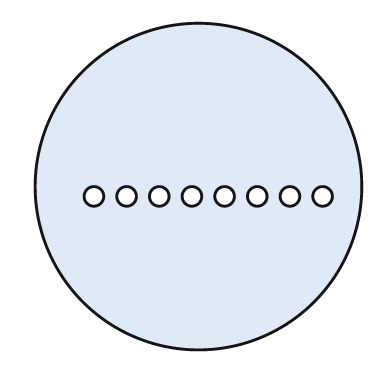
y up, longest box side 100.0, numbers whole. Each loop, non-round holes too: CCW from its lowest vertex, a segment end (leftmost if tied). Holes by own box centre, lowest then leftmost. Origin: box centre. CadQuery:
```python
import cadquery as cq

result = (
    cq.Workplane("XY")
    .moveTo(0.0, 0.0)
    .circle(50.0)
    .moveTo(-32.0, -3.0)
    .circle(3.0)
    .moveTo(-22.0, -3.0)
    .circle(3.0)
    .moveTo(-12.0, -3.0)
    .circle(3.0)
    .moveTo(-2.0, -3.0)
    .circle(3.0)
    .moveTo(8.0, -3.0)
    .circle(3.0)
    .moveTo(18.0, -3.0)
    .circle(3.0)
    .moveTo(28.0, -3.0)
    .circle(3.0)
    .moveTo(38.0, -3.0)
    .circle(3.0)
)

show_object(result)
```